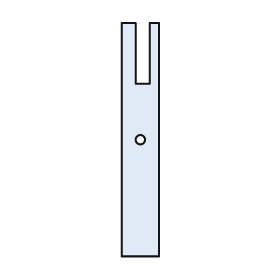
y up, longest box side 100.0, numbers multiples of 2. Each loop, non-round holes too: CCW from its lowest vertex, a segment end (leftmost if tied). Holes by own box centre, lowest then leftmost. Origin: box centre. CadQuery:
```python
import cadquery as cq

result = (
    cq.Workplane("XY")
    .moveTo(-8.0, -50.0)
    .lineTo(8.0, -50.0)
    .lineTo(8.0, 50.0)
    .lineTo(4.0, 50.0)
    .lineTo(4.0, 24.0)
    .lineTo(-2.0, 24.0)
    .lineTo(-2.0, 50.0)
    .lineTo(-8.0, 50.0)
    .close()
    .moveTo(0.0, 0.0)
    .circle(2.0)
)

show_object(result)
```